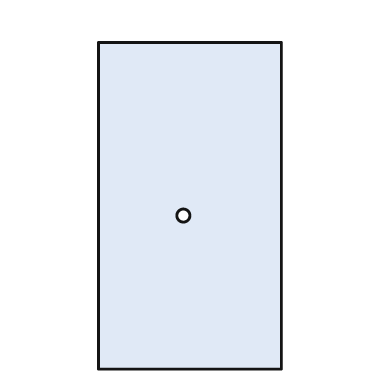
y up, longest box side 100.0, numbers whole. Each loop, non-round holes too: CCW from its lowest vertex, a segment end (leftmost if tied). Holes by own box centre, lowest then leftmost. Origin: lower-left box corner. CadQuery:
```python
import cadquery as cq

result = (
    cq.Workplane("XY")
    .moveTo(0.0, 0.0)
    .lineTo(56.0, 0.0)
    .lineTo(56.0, 100.0)
    .lineTo(0.0, 100.0)
    .close()
    .moveTo(26.0, 47.0)
    .circle(2.0)
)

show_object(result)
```